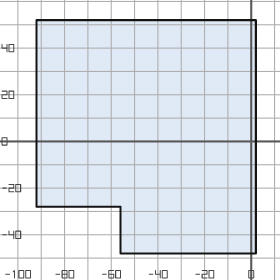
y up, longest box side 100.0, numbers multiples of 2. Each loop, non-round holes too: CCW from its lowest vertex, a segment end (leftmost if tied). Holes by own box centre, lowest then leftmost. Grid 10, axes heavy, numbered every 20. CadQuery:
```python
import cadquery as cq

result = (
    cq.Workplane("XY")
    .moveTo(-56.0, -48.0)
    .lineTo(2.0, -48.0)
    .lineTo(2.0, 52.0)
    .lineTo(-92.0, 52.0)
    .lineTo(-92.0, -28.0)
    .lineTo(-56.0, -28.0)
    .close()
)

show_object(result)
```